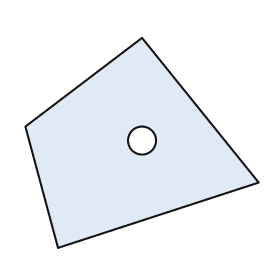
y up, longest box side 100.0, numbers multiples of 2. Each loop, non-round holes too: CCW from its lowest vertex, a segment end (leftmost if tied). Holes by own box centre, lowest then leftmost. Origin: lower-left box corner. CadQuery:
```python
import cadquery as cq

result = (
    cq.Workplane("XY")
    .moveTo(14.0, 0.0)
    .lineTo(100.0, 28.0)
    .lineTo(50.0, 90.0)
    .lineTo(0.0, 52.0)
    .close()
    .moveTo(50.0, 46.0)
    .circle(6.0)
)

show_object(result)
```